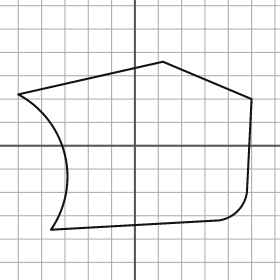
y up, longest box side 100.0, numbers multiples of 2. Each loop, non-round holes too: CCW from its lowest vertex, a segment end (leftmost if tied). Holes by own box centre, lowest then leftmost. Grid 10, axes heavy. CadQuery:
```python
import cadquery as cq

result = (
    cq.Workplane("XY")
    .moveTo(-36.0, -36.0)
    .lineTo(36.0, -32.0)
    .threePointArc((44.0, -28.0), (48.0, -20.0))
    .lineTo(50.0, 20.0)
    .lineTo(12.0, 36.0)
    .lineTo(-50.0, 22.0)
    .threePointArc((-30.0, -4.0), (-36.0, -36.0))
    .close()
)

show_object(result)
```